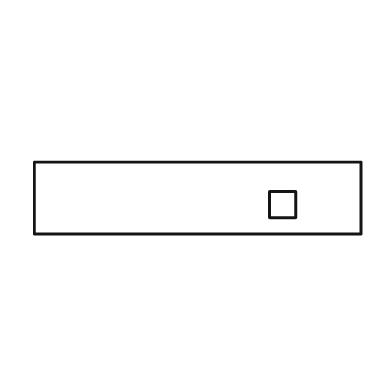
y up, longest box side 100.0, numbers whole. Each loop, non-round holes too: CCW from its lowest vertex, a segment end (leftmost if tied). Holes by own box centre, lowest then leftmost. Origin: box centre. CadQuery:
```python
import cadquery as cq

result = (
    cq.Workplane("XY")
    .moveTo(-50.0, -11.0)
    .lineTo(50.0, -11.0)
    .lineTo(50.0, 11.0)
    .lineTo(-50.0, 11.0)
    .close()
    .moveTo(22.0, -6.0)
    .lineTo(30.0, -6.0)
    .lineTo(30.0, 2.0)
    .lineTo(22.0, 2.0)
    .close()
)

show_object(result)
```